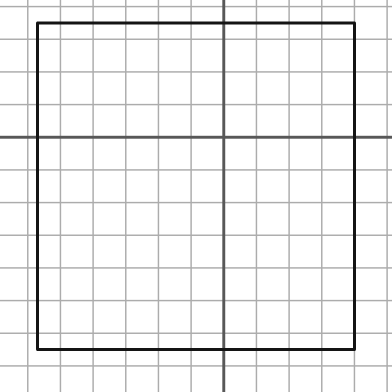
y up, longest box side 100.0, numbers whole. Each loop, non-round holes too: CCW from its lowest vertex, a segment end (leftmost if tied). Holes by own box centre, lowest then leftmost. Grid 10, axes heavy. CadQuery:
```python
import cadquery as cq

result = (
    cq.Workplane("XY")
    .moveTo(-57.0, -65.0)
    .lineTo(40.0, -65.0)
    .lineTo(40.0, 35.0)
    .lineTo(-57.0, 35.0)
    .close()
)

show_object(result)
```